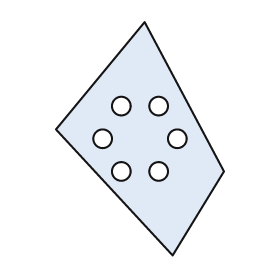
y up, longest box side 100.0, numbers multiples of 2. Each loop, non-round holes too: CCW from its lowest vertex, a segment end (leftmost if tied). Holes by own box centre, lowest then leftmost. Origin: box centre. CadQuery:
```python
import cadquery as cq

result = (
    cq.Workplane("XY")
    .moveTo(14.0, -50.0)
    .lineTo(36.0, -14.0)
    .lineTo(2.0, 50.0)
    .lineTo(-36.0, 4.0)
    .close()
    .moveTo(-8.0, -14.0)
    .circle(4.0)
    .moveTo(8.0, -14.0)
    .circle(4.0)
    .moveTo(-16.0, 0.0)
    .circle(4.0)
    .moveTo(16.0, 0.0)
    .circle(4.0)
    .moveTo(-8.0, 14.0)
    .circle(4.0)
    .moveTo(8.0, 14.0)
    .circle(4.0)
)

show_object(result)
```